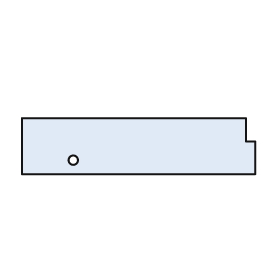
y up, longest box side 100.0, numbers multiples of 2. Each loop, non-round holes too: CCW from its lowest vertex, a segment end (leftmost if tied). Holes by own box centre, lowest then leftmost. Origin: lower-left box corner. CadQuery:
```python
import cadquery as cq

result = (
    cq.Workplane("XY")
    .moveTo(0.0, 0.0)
    .lineTo(100.0, 0.0)
    .lineTo(100.0, 14.0)
    .lineTo(96.0, 14.0)
    .lineTo(96.0, 24.0)
    .lineTo(0.0, 24.0)
    .close()
    .moveTo(22.0, 6.0)
    .circle(2.0)
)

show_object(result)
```